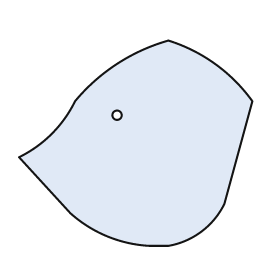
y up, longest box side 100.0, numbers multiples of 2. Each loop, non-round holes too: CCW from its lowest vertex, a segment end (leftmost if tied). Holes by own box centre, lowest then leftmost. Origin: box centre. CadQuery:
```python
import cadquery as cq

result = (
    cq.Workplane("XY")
    .moveTo(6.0, -44.0)
    .lineTo(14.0, -44.0)
    .threePointArc((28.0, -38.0), (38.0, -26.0))
    .lineTo(50.0, 18.0)
    .threePointArc((34.0, 34.0), (14.0, 44.0))
    .threePointArc((-8.0, 34.0), (-26.0, 18.0))
    .threePointArc((-36.0, 4.0), (-50.0, -6.0))
    .lineTo(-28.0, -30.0)
    .threePointArc((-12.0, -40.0), (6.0, -44.0))
    .close()
    .moveTo(-8.0, 12.0)
    .circle(2.0)
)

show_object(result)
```